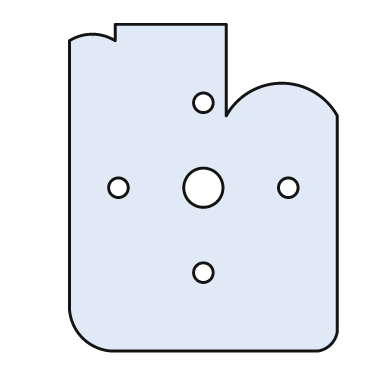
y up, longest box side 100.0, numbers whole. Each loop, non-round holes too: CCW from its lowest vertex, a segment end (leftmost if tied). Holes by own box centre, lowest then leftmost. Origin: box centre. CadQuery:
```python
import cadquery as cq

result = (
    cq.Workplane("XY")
    .moveTo(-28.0, -50.0)
    .lineTo(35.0, -50.0)
    .threePointArc((39.0, -48.0), (41.0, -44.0))
    .lineTo(41.0, 22.0)
    .threePointArc((24.0, 32.0), (7.0, 22.0))
    .lineTo(7.0, 50.0)
    .lineTo(-27.0, 50.0)
    .lineTo(-27.0, 45.0)
    .threePointArc((-34.0, 47.0), (-41.0, 45.0))
    .lineTo(-41.0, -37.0)
    .threePointArc((-37.0, -46.0), (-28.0, -50.0))
    .close()
    .moveTo(0.0, -26.0)
    .circle(3.0)
    .moveTo(-26.0, 0.0)
    .circle(3.0)
    .moveTo(0.0, 0.0)
    .circle(6.0)
    .moveTo(26.0, 0.0)
    .circle(3.0)
    .moveTo(0.0, 26.0)
    .circle(3.0)
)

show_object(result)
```